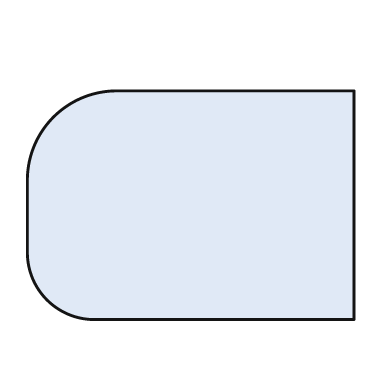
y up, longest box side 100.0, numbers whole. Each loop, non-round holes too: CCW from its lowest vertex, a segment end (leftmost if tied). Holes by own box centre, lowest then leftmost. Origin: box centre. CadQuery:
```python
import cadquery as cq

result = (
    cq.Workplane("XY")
    .moveTo(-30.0, -35.0)
    .lineTo(50.0, -35.0)
    .lineTo(50.0, 35.0)
    .lineTo(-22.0, 35.0)
    .threePointArc((-42.0, 27.0), (-50.0, 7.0))
    .lineTo(-50.0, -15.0)
    .threePointArc((-44.0, -29.0), (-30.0, -35.0))
    .close()
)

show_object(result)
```